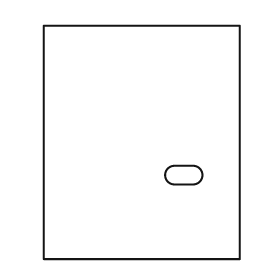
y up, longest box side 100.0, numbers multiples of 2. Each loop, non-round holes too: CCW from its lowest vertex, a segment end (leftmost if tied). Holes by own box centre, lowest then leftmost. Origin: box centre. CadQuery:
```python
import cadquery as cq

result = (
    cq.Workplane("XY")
    .moveTo(-42.0, -50.0)
    .lineTo(42.0, -50.0)
    .lineTo(42.0, 50.0)
    .lineTo(-42.0, 50.0)
    .close()
    .moveTo(14.0, -18.0)
    .lineTo(22.0, -18.0)
    .threePointArc((26.0, -14.0), (22.0, -10.0))
    .lineTo(14.0, -10.0)
    .threePointArc((10.0, -14.0), (14.0, -18.0))
    .close()
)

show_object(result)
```